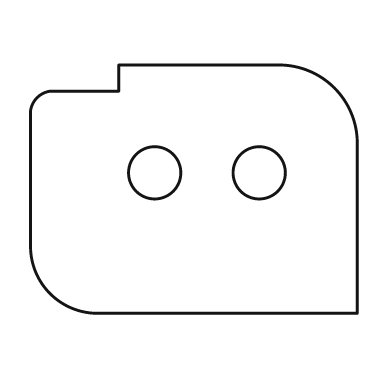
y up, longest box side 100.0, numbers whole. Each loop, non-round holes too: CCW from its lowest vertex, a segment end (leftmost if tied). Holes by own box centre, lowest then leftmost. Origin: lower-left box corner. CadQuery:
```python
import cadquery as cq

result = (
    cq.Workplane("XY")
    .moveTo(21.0, 0.0)
    .lineTo(100.0, 0.0)
    .lineTo(100.0, 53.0)
    .threePointArc((93.0, 69.0), (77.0, 76.0))
    .lineTo(27.0, 76.0)
    .lineTo(27.0, 68.0)
    .lineTo(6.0, 68.0)
    .threePointArc((2.0, 66.0), (0.0, 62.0))
    .lineTo(0.0, 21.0)
    .threePointArc((6.0, 6.0), (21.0, 0.0))
    .close()
    .moveTo(38.0, 43.0)
    .circle(8.0)
    .moveTo(70.0, 43.0)
    .circle(8.0)
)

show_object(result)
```